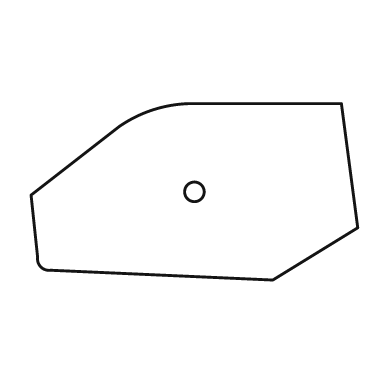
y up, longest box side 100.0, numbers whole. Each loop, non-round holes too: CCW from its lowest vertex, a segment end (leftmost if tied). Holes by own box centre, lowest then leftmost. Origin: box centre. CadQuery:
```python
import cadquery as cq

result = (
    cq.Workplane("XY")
    .moveTo(24.0, -27.0)
    .lineTo(50.0, -11.0)
    .lineTo(45.0, 27.0)
    .lineTo(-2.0, 27.0)
    .threePointArc((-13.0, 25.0), (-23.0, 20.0))
    .lineTo(-50.0, -1.0)
    .lineTo(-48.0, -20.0)
    .threePointArc((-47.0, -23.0), (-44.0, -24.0))
    .close()
    .moveTo(0.0, 0.0)
    .circle(3.0)
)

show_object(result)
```